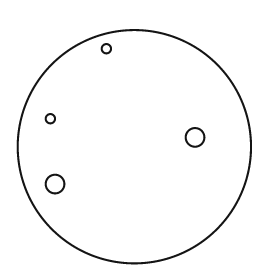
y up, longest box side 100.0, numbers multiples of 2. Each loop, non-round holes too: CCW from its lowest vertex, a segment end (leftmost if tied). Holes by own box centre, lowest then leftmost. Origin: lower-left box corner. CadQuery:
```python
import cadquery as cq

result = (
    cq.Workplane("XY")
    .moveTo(50.0, 50.0)
    .circle(50.0)
    .moveTo(16.0, 34.0)
    .circle(4.0)
    .moveTo(76.0, 54.0)
    .circle(4.0)
    .moveTo(14.0, 62.0)
    .circle(2.0)
    .moveTo(38.0, 92.0)
    .circle(2.0)
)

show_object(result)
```